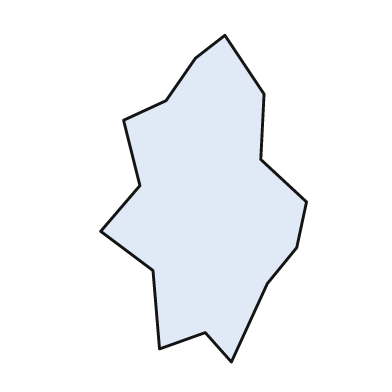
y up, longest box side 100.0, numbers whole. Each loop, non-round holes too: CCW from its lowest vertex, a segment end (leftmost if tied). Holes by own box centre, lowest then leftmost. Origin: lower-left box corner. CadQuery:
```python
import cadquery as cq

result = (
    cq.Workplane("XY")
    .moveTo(40.0, 0.0)
    .lineTo(51.0, 24.0)
    .lineTo(60.0, 35.0)
    .lineTo(63.0, 49.0)
    .lineTo(49.0, 62.0)
    .lineTo(50.0, 82.0)
    .lineTo(38.0, 100.0)
    .lineTo(29.0, 93.0)
    .lineTo(20.0, 80.0)
    .lineTo(7.0, 74.0)
    .lineTo(12.0, 54.0)
    .lineTo(0.0, 40.0)
    .lineTo(16.0, 28.0)
    .lineTo(18.0, 4.0)
    .lineTo(32.0, 9.0)
    .close()
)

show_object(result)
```